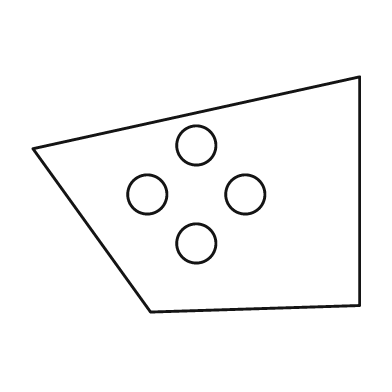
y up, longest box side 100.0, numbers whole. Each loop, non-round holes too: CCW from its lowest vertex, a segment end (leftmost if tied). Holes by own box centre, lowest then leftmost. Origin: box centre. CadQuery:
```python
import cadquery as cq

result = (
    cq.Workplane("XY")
    .moveTo(-14.0, -36.0)
    .lineTo(50.0, -34.0)
    .lineTo(50.0, 36.0)
    .lineTo(-50.0, 14.0)
    .close()
    .moveTo(0.0, -15.0)
    .circle(6.0)
    .moveTo(-15.0, 0.0)
    .circle(6.0)
    .moveTo(15.0, 0.0)
    .circle(6.0)
    .moveTo(0.0, 15.0)
    .circle(6.0)
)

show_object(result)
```